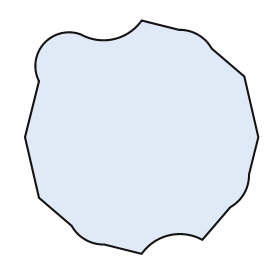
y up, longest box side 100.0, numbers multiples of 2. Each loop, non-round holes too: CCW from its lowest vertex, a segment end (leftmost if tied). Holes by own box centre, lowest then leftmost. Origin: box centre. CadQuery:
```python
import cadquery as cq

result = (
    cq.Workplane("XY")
    .moveTo(0.0, -50.0)
    .threePointArc((12.0, -42.0), (26.0, -44.0))
    .lineTo(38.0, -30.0)
    .threePointArc((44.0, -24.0), (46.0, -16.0))
    .lineTo(50.0, 0.0)
    .lineTo(44.0, 26.0)
    .lineTo(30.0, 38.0)
    .threePointArc((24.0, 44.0), (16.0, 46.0))
    .lineTo(0.0, 50.0)
    .threePointArc((-12.0, 42.0), (-26.0, 44.0))
    .threePointArc((-42.0, 40.0), (-44.0, 24.0))
    .lineTo(-50.0, 0.0)
    .lineTo(-44.0, -26.0)
    .lineTo(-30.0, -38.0)
    .threePointArc((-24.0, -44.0), (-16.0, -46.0))
    .close()
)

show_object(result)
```